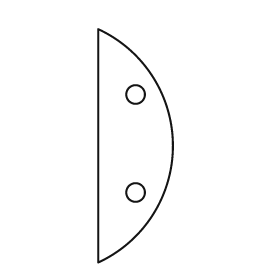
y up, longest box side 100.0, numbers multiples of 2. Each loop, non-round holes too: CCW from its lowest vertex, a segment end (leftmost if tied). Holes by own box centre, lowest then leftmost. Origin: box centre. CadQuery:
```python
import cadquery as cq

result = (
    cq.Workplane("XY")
    .moveTo(-16.0, -50.0)
    .threePointArc((16.0, 0.0), (-16.0, 50.0))
    .close()
    .moveTo(0.0, -20.0)
    .circle(4.0)
    .moveTo(0.0, 22.0)
    .circle(4.0)
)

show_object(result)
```